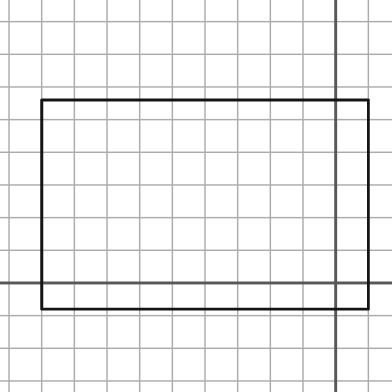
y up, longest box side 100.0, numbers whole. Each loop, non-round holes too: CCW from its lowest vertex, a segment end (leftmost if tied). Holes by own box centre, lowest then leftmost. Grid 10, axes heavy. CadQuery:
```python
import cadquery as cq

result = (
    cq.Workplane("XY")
    .moveTo(-90.0, -8.0)
    .lineTo(10.0, -8.0)
    .lineTo(10.0, 56.0)
    .lineTo(-90.0, 56.0)
    .close()
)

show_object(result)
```